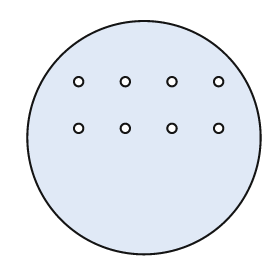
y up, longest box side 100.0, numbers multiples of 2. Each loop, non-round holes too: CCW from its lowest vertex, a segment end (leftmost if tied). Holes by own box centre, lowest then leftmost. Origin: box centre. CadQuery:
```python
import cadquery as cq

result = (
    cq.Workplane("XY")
    .moveTo(0.0, 0.0)
    .circle(50.0)
    .moveTo(-28.0, 4.0)
    .circle(2.0)
    .moveTo(-8.0, 4.0)
    .circle(2.0)
    .moveTo(12.0, 4.0)
    .circle(2.0)
    .moveTo(32.0, 4.0)
    .circle(2.0)
    .moveTo(-28.0, 24.0)
    .circle(2.0)
    .moveTo(-8.0, 24.0)
    .circle(2.0)
    .moveTo(12.0, 24.0)
    .circle(2.0)
    .moveTo(32.0, 24.0)
    .circle(2.0)
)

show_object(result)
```